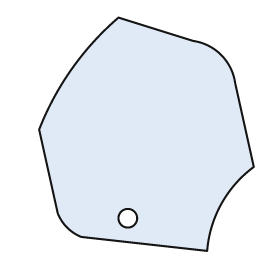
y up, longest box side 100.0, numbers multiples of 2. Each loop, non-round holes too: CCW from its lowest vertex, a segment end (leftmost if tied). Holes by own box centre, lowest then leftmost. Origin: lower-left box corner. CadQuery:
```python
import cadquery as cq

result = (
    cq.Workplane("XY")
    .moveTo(72.0, 0.0)
    .threePointArc((78.0, 20.0), (92.0, 36.0))
    .lineTo(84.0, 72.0)
    .threePointArc((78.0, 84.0), (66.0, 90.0))
    .lineTo(34.0, 100.0)
    .threePointArc((14.0, 78.0), (0.0, 52.0))
    .lineTo(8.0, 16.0)
    .threePointArc((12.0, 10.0), (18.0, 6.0))
    .close()
    .moveTo(38.0, 14.0)
    .circle(4.0)
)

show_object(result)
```